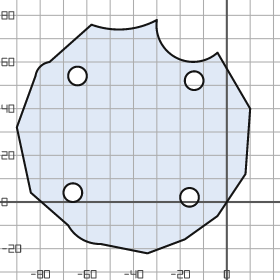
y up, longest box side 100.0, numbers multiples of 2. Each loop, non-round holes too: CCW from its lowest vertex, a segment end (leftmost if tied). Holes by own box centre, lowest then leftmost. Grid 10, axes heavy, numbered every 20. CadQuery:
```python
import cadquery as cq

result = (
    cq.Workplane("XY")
    .moveTo(-34.0, -22.0)
    .lineTo(-18.0, -16.0)
    .lineTo(-4.0, -6.0)
    .lineTo(8.0, 12.0)
    .lineTo(10.0, 40.0)
    .lineTo(-4.0, 64.0)
    .threePointArc((-22.0, 62.0), (-30.0, 78.0))
    .threePointArc((-44.0, 74.0), (-58.0, 76.0))
    .lineTo(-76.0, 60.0)
    .threePointArc((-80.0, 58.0), (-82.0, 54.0))
    .lineTo(-90.0, 32.0)
    .lineTo(-84.0, 4.0)
    .lineTo(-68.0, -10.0)
    .threePointArc((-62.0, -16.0), (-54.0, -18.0))
    .close()
    .moveTo(-16.0, 2.0)
    .circle(4.0)
    .moveTo(-66.0, 4.0)
    .circle(4.0)
    .moveTo(-14.0, 52.0)
    .circle(4.0)
    .moveTo(-64.0, 54.0)
    .circle(4.0)
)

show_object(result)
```